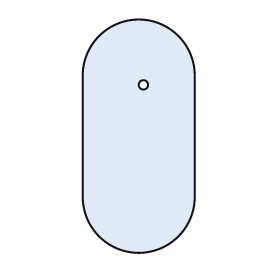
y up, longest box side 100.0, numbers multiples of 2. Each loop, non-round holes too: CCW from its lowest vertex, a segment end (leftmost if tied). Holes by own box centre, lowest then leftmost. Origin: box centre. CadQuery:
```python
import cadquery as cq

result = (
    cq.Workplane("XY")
    .moveTo(-24.0, -26.0)
    .threePointArc((0.0, -50.0), (24.0, -26.0))
    .lineTo(24.0, 26.0)
    .threePointArc((0.0, 50.0), (-24.0, 26.0))
    .close()
    .moveTo(2.0, 22.0)
    .circle(2.0)
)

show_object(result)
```